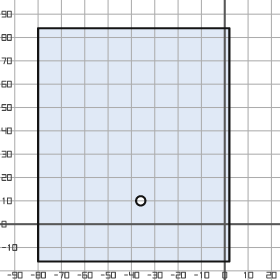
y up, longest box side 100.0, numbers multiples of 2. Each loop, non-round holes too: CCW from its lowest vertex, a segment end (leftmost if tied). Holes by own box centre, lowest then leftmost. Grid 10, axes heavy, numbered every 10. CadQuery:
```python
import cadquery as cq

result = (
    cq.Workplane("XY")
    .moveTo(-80.0, -16.0)
    .lineTo(2.0, -16.0)
    .lineTo(2.0, 84.0)
    .lineTo(-80.0, 84.0)
    .close()
    .moveTo(-36.0, 10.0)
    .circle(2.0)
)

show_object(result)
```